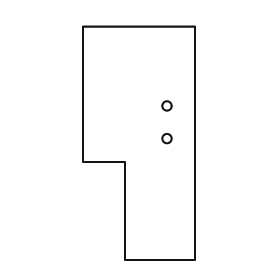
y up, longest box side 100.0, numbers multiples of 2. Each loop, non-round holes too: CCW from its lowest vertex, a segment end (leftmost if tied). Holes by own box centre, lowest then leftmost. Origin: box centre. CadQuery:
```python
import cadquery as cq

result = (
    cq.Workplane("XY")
    .moveTo(-6.0, -50.0)
    .lineTo(24.0, -50.0)
    .lineTo(24.0, 50.0)
    .lineTo(-24.0, 50.0)
    .lineTo(-24.0, -8.0)
    .lineTo(-6.0, -8.0)
    .close()
    .moveTo(12.0, 2.0)
    .circle(2.0)
    .moveTo(12.0, 16.0)
    .circle(2.0)
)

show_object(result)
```